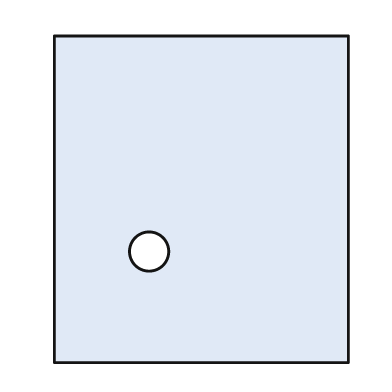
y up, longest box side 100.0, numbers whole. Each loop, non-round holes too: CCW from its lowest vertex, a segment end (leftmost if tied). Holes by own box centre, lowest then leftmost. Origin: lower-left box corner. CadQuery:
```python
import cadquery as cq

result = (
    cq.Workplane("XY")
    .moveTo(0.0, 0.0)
    .lineTo(90.0, 0.0)
    .lineTo(90.0, 100.0)
    .lineTo(0.0, 100.0)
    .close()
    .moveTo(29.0, 34.0)
    .circle(6.0)
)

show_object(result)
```